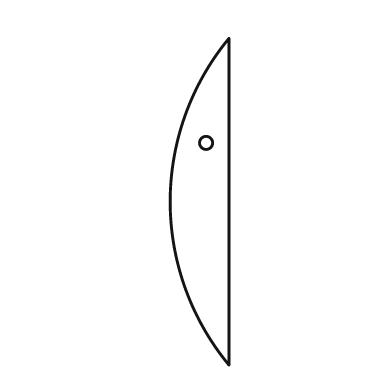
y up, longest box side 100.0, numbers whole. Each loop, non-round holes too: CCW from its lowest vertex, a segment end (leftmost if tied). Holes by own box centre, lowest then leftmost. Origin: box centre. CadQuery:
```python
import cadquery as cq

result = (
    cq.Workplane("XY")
    .moveTo(9.0, -50.0)
    .lineTo(9.0, 50.0)
    .threePointArc((-9.0, 0.0), (9.0, -50.0))
    .close()
    .moveTo(2.0, 18.0)
    .circle(2.0)
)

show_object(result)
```